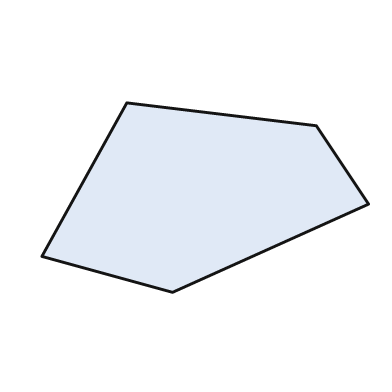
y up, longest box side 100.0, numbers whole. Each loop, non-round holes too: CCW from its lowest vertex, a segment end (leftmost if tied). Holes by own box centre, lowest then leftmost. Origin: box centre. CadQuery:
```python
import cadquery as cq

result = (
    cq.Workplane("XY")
    .moveTo(-10.0, -29.0)
    .lineTo(50.0, -2.0)
    .lineTo(34.0, 22.0)
    .lineTo(-24.0, 29.0)
    .lineTo(-50.0, -18.0)
    .close()
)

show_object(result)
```